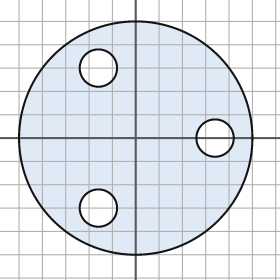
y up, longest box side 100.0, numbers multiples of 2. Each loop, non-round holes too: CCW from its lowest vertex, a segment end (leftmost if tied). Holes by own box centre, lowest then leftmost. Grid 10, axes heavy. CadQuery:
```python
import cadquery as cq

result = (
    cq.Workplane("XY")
    .moveTo(0.0, 0.0)
    .circle(50.0)
    .moveTo(-16.0, -30.0)
    .circle(8.0)
    .moveTo(34.0, 0.0)
    .circle(8.0)
    .moveTo(-16.0, 30.0)
    .circle(8.0)
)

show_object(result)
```